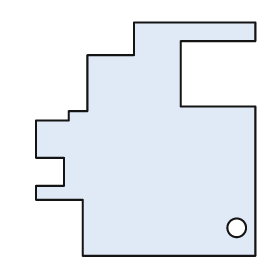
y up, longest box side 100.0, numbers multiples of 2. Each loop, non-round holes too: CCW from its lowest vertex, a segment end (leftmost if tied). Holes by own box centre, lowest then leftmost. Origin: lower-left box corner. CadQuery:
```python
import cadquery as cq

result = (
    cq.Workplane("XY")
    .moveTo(20.0, 0.0)
    .lineTo(94.0, 0.0)
    .lineTo(94.0, 64.0)
    .lineTo(62.0, 64.0)
    .lineTo(62.0, 92.0)
    .lineTo(94.0, 92.0)
    .lineTo(94.0, 100.0)
    .lineTo(42.0, 100.0)
    .lineTo(42.0, 86.0)
    .lineTo(22.0, 86.0)
    .lineTo(22.0, 62.0)
    .lineTo(14.0, 62.0)
    .lineTo(14.0, 58.0)
    .lineTo(0.0, 58.0)
    .lineTo(0.0, 42.0)
    .lineTo(12.0, 42.0)
    .lineTo(12.0, 30.0)
    .lineTo(0.0, 30.0)
    .lineTo(0.0, 24.0)
    .lineTo(20.0, 24.0)
    .close()
    .moveTo(86.0, 12.0)
    .circle(4.0)
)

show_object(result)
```